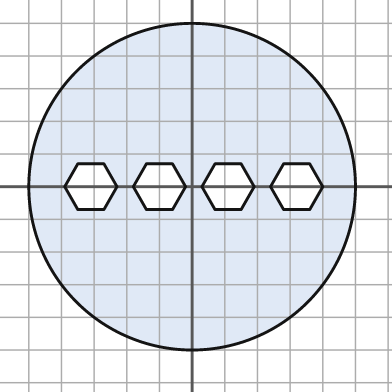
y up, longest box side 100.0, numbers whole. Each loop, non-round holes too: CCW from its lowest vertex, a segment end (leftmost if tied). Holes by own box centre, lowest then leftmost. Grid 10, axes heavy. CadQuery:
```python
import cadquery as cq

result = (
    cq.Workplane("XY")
    .moveTo(0.0, 0.0)
    .circle(50.0)
    .moveTo(-35.0, -7.0)
    .lineTo(-27.0, -7.0)
    .lineTo(-23.0, 0.0)
    .lineTo(-27.0, 7.0)
    .lineTo(-35.0, 7.0)
    .lineTo(-39.0, 0.0)
    .close()
    .moveTo(-14.0, -7.0)
    .lineTo(-6.0, -7.0)
    .lineTo(-2.0, 0.0)
    .lineTo(-6.0, 7.0)
    .lineTo(-14.0, 7.0)
    .lineTo(-18.0, 0.0)
    .close()
    .moveTo(7.0, -7.0)
    .lineTo(15.0, -7.0)
    .lineTo(19.0, 0.0)
    .lineTo(15.0, 7.0)
    .lineTo(7.0, 7.0)
    .lineTo(3.0, 0.0)
    .close()
    .moveTo(28.0, -7.0)
    .lineTo(36.0, -7.0)
    .lineTo(40.0, 0.0)
    .lineTo(36.0, 7.0)
    .lineTo(28.0, 7.0)
    .lineTo(24.0, 0.0)
    .close()
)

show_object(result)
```